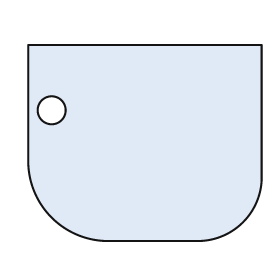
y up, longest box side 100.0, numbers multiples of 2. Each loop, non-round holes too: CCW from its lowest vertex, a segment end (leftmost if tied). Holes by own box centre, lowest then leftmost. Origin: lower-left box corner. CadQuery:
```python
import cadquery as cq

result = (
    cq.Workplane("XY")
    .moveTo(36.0, 0.0)
    .lineTo(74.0, 0.0)
    .threePointArc((92.0, 8.0), (100.0, 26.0))
    .lineTo(100.0, 84.0)
    .lineTo(0.0, 84.0)
    .lineTo(0.0, 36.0)
    .threePointArc((10.0, 10.0), (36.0, 0.0))
    .close()
    .moveTo(10.0, 56.0)
    .circle(6.0)
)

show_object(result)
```